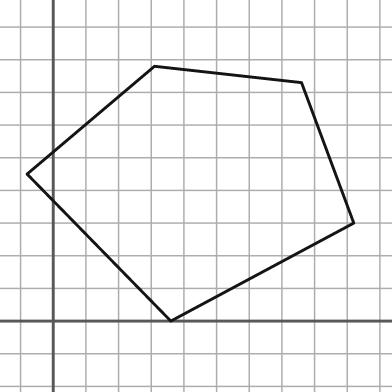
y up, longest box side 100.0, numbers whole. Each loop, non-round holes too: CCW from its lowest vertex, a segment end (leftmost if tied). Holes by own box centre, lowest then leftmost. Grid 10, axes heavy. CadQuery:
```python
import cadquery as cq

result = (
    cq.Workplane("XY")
    .moveTo(36.0, 0.0)
    .lineTo(92.0, 30.0)
    .lineTo(76.0, 73.0)
    .lineTo(31.0, 78.0)
    .lineTo(-8.0, 45.0)
    .close()
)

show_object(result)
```